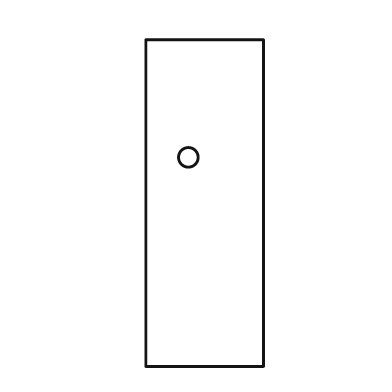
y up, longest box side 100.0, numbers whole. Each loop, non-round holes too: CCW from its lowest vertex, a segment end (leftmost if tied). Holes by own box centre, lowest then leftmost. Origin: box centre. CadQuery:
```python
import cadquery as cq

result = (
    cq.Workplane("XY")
    .moveTo(-18.0, -50.0)
    .lineTo(18.0, -50.0)
    .lineTo(18.0, 50.0)
    .lineTo(-18.0, 50.0)
    .close()
    .moveTo(-5.0, 14.0)
    .circle(3.0)
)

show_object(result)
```